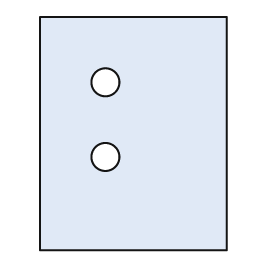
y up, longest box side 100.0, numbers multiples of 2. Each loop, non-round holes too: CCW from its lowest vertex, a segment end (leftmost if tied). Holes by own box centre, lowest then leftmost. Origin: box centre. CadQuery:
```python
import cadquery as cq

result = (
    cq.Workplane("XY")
    .moveTo(-40.0, -50.0)
    .lineTo(40.0, -50.0)
    .lineTo(40.0, 50.0)
    .lineTo(-40.0, 50.0)
    .close()
    .moveTo(-12.0, -10.0)
    .circle(6.0)
    .moveTo(-12.0, 22.0)
    .circle(6.0)
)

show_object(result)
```